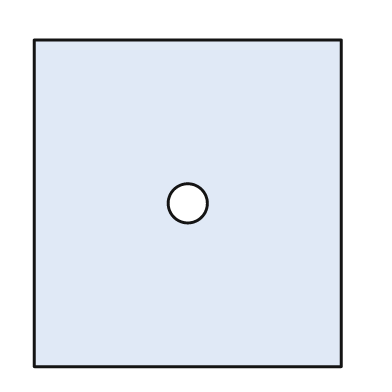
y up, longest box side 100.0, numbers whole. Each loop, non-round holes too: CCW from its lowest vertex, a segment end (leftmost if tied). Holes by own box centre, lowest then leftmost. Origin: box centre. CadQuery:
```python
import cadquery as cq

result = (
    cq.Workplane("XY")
    .moveTo(-47.0, -50.0)
    .lineTo(47.0, -50.0)
    .lineTo(47.0, 50.0)
    .lineTo(-47.0, 50.0)
    .close()
    .moveTo(0.0, 0.0)
    .circle(6.0)
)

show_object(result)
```